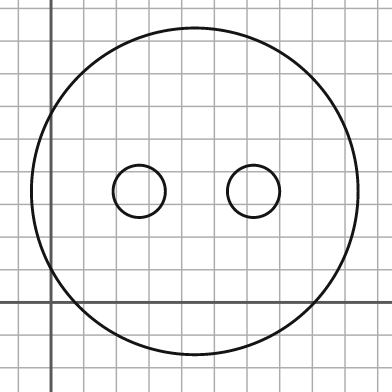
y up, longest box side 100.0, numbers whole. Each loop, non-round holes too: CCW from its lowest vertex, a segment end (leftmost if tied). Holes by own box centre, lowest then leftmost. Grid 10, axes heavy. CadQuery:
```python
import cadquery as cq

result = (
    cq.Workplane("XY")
    .moveTo(44.0, 34.0)
    .circle(50.0)
    .moveTo(27.0, 34.0)
    .circle(8.0)
    .moveTo(62.0, 34.0)
    .circle(8.0)
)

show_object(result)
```